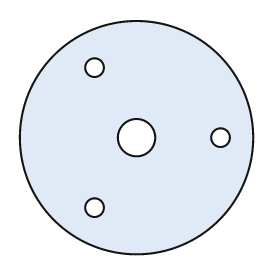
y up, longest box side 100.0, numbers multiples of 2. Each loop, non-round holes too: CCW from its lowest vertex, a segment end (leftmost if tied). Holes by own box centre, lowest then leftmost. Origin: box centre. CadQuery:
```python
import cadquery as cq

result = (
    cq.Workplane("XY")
    .moveTo(0.0, 0.0)
    .circle(50.0)
    .moveTo(-18.0, -30.0)
    .circle(4.0)
    .moveTo(0.0, 0.0)
    .circle(8.0)
    .moveTo(36.0, 0.0)
    .circle(4.0)
    .moveTo(-18.0, 30.0)
    .circle(4.0)
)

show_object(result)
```